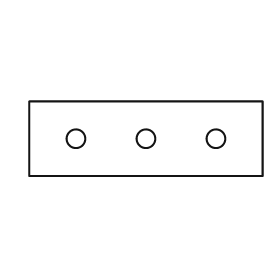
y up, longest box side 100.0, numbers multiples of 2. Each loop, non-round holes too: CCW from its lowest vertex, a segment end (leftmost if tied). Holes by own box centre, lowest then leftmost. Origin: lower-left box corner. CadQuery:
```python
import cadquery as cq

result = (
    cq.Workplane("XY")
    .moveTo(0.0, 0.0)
    .lineTo(100.0, 0.0)
    .lineTo(100.0, 32.0)
    .lineTo(0.0, 32.0)
    .close()
    .moveTo(20.0, 16.0)
    .circle(4.0)
    .moveTo(50.0, 16.0)
    .circle(4.0)
    .moveTo(80.0, 16.0)
    .circle(4.0)
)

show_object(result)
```